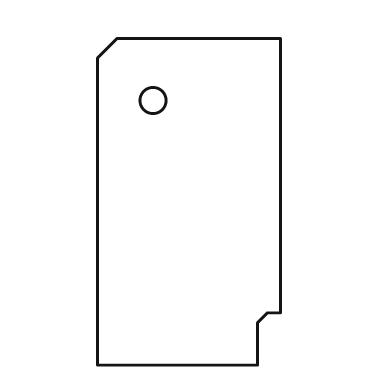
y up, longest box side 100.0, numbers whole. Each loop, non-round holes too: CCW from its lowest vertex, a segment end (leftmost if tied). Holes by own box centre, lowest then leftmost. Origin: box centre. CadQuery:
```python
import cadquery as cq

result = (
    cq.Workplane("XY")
    .moveTo(-28.0, -50.0)
    .lineTo(21.0, -50.0)
    .lineTo(21.0, -37.0)
    .lineTo(24.0, -34.0)
    .lineTo(28.0, -34.0)
    .lineTo(28.0, 50.0)
    .lineTo(-22.0, 50.0)
    .lineTo(-28.0, 44.0)
    .close()
    .moveTo(-11.0, 31.0)
    .circle(4.0)
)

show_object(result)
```